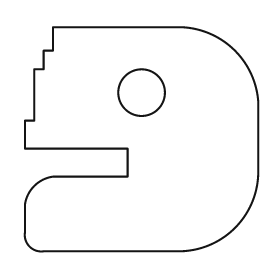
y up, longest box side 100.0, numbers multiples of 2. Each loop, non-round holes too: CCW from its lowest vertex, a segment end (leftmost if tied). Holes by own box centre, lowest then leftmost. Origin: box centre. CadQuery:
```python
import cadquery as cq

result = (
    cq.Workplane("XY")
    .moveTo(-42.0, -48.0)
    .lineTo(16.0, -48.0)
    .threePointArc((40.0, -38.0), (50.0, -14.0))
    .lineTo(50.0, 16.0)
    .threePointArc((40.0, 38.0), (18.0, 48.0))
    .lineTo(-38.0, 48.0)
    .lineTo(-38.0, 38.0)
    .lineTo(-42.0, 38.0)
    .lineTo(-42.0, 30.0)
    .lineTo(-46.0, 30.0)
    .lineTo(-46.0, 8.0)
    .lineTo(-50.0, 8.0)
    .lineTo(-50.0, -4.0)
    .lineTo(-6.0, -4.0)
    .lineTo(-6.0, -16.0)
    .lineTo(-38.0, -16.0)
    .threePointArc((-46.0, -20.0), (-50.0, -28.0))
    .lineTo(-50.0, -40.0)
    .threePointArc((-48.0, -46.0), (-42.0, -48.0))
    .close()
    .moveTo(0.0, 20.0)
    .circle(10.0)
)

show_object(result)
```